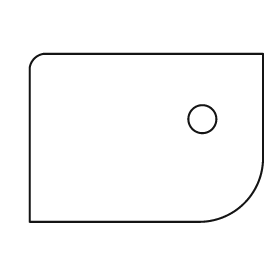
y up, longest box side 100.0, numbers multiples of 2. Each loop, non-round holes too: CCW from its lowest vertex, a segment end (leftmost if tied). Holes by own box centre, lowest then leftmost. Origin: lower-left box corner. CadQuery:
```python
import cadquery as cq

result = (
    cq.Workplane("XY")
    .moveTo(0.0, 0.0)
    .lineTo(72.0, 0.0)
    .threePointArc((92.0, 8.0), (100.0, 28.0))
    .lineTo(100.0, 72.0)
    .lineTo(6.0, 72.0)
    .threePointArc((2.0, 70.0), (0.0, 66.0))
    .close()
    .moveTo(74.0, 44.0)
    .circle(6.0)
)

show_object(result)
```